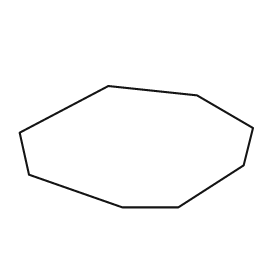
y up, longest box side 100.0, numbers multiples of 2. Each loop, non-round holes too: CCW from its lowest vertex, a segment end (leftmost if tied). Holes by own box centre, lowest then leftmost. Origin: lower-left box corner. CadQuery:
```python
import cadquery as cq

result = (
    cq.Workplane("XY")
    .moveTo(44.0, 0.0)
    .lineTo(68.0, 0.0)
    .lineTo(96.0, 18.0)
    .lineTo(100.0, 34.0)
    .lineTo(76.0, 48.0)
    .lineTo(38.0, 52.0)
    .lineTo(0.0, 32.0)
    .lineTo(4.0, 14.0)
    .close()
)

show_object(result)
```